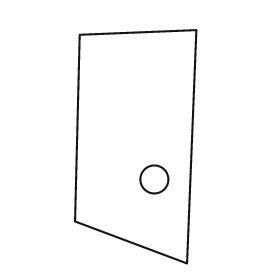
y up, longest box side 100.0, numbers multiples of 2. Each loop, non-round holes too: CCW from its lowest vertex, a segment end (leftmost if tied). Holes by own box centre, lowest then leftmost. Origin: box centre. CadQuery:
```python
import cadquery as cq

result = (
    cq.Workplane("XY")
    .moveTo(22.0, -50.0)
    .lineTo(26.0, 50.0)
    .lineTo(-24.0, 48.0)
    .lineTo(-26.0, -32.0)
    .close()
    .moveTo(8.0, -14.0)
    .circle(6.0)
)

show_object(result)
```